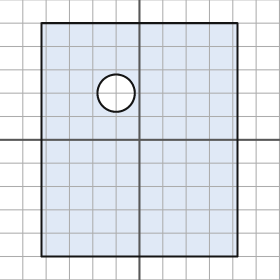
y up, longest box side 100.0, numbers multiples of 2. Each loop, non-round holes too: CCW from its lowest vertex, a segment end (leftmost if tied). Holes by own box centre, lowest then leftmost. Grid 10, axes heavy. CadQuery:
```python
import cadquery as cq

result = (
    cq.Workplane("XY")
    .moveTo(-42.0, -50.0)
    .lineTo(42.0, -50.0)
    .lineTo(42.0, 50.0)
    .lineTo(-42.0, 50.0)
    .close()
    .moveTo(-10.0, 20.0)
    .circle(8.0)
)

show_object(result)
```